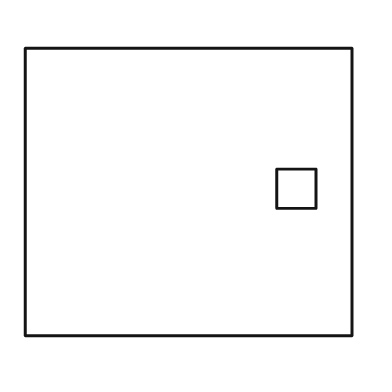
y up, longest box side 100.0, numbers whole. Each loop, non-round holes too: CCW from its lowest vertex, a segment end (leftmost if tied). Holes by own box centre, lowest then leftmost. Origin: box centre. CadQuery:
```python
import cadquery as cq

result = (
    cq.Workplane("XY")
    .moveTo(-50.0, -44.0)
    .lineTo(50.0, -44.0)
    .lineTo(50.0, 44.0)
    .lineTo(-50.0, 44.0)
    .close()
    .moveTo(27.0, -5.0)
    .lineTo(39.0, -5.0)
    .lineTo(39.0, 7.0)
    .lineTo(27.0, 7.0)
    .close()
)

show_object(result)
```